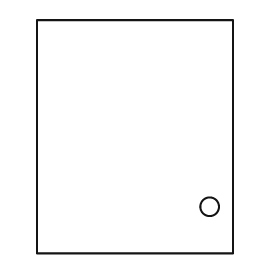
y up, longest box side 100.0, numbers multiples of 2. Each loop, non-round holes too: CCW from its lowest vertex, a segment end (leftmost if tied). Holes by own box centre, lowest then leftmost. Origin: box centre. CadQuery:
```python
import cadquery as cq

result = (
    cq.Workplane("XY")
    .moveTo(-42.0, -50.0)
    .lineTo(42.0, -50.0)
    .lineTo(42.0, 50.0)
    .lineTo(-42.0, 50.0)
    .close()
    .moveTo(32.0, -30.0)
    .circle(4.0)
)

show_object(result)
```